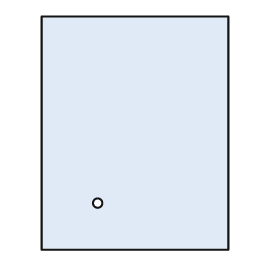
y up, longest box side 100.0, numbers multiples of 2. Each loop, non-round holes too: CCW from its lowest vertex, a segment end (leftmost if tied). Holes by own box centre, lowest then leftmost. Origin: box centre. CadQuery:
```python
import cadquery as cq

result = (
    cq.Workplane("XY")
    .moveTo(-40.0, -50.0)
    .lineTo(40.0, -50.0)
    .lineTo(40.0, 50.0)
    .lineTo(-40.0, 50.0)
    .close()
    .moveTo(-16.0, -30.0)
    .circle(2.0)
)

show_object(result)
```